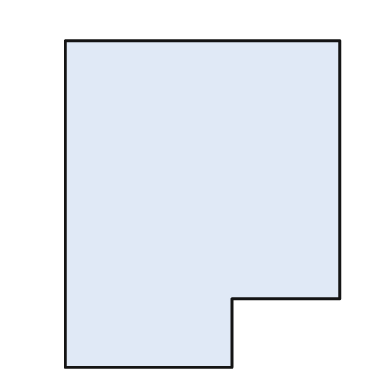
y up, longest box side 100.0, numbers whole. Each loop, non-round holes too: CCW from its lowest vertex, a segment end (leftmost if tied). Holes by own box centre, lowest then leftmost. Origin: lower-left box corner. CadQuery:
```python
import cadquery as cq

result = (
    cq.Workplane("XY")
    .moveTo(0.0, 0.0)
    .lineTo(51.0, 0.0)
    .lineTo(51.0, 21.0)
    .lineTo(84.0, 21.0)
    .lineTo(84.0, 100.0)
    .lineTo(0.0, 100.0)
    .close()
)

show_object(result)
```